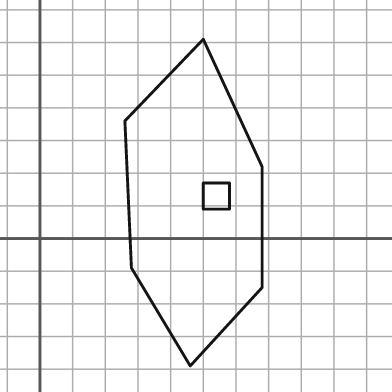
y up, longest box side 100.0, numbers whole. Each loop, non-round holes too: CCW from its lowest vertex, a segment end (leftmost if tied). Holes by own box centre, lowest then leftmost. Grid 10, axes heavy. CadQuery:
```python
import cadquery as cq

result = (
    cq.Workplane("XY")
    .moveTo(46.0, -39.0)
    .lineTo(68.0, -15.0)
    .lineTo(68.0, 22.0)
    .lineTo(50.0, 61.0)
    .lineTo(26.0, 36.0)
    .lineTo(28.0, -9.0)
    .close()
    .moveTo(50.0, 9.0)
    .lineTo(58.0, 9.0)
    .lineTo(58.0, 17.0)
    .lineTo(50.0, 17.0)
    .close()
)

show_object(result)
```